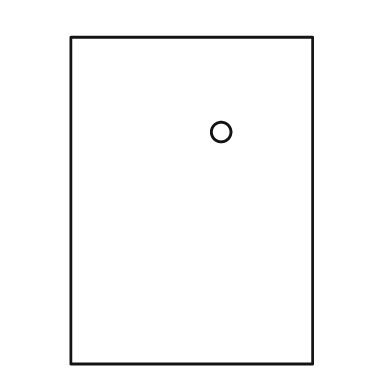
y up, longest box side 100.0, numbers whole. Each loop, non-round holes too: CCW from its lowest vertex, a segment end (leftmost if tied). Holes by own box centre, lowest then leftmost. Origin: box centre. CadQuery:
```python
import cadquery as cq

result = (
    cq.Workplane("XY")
    .moveTo(-37.0, -50.0)
    .lineTo(37.0, -50.0)
    .lineTo(37.0, 50.0)
    .lineTo(-37.0, 50.0)
    .close()
    .moveTo(9.0, 21.0)
    .circle(3.0)
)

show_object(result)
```